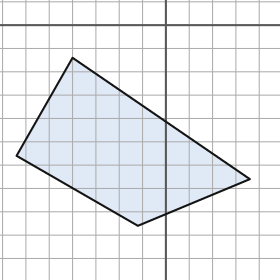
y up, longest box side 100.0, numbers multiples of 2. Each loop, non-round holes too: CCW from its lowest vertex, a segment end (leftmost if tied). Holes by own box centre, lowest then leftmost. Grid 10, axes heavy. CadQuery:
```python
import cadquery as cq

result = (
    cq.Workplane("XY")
    .moveTo(-12.0, -86.0)
    .lineTo(36.0, -66.0)
    .lineTo(-40.0, -14.0)
    .lineTo(-64.0, -56.0)
    .close()
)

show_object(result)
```